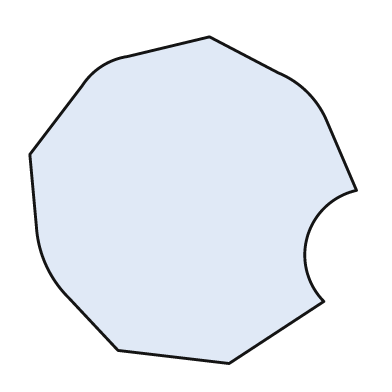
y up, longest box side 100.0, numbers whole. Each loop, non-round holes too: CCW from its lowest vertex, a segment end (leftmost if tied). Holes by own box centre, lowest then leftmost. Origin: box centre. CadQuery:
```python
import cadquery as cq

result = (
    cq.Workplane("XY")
    .moveTo(11.0, -50.0)
    .lineTo(40.0, -31.0)
    .threePointArc((35.0, -11.0), (50.0, 3.0))
    .lineTo(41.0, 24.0)
    .threePointArc((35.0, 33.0), (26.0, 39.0))
    .lineTo(5.0, 50.0)
    .lineTo(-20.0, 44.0)
    .threePointArc((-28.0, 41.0), (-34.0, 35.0))
    .lineTo(-50.0, 14.0)
    .lineTo(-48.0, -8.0)
    .threePointArc((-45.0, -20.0), (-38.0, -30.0))
    .lineTo(-23.0, -46.0)
    .close()
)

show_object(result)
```